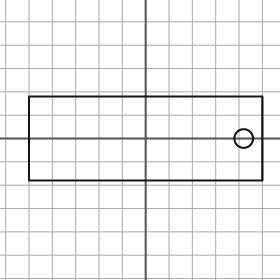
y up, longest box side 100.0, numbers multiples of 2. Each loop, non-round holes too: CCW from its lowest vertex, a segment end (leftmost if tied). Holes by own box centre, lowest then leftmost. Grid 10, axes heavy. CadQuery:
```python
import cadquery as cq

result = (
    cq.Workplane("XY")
    .moveTo(-50.0, -18.0)
    .lineTo(50.0, -18.0)
    .lineTo(50.0, 18.0)
    .lineTo(-50.0, 18.0)
    .close()
    .moveTo(42.0, 0.0)
    .circle(4.0)
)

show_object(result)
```